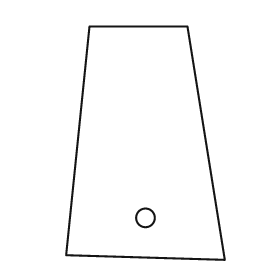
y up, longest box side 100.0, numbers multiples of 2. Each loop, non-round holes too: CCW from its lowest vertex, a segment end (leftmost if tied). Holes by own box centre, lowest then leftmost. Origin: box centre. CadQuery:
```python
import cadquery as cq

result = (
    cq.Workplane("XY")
    .moveTo(34.0, -50.0)
    .lineTo(18.0, 50.0)
    .lineTo(-24.0, 50.0)
    .lineTo(-34.0, -48.0)
    .close()
    .moveTo(0.0, -32.0)
    .circle(4.0)
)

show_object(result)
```